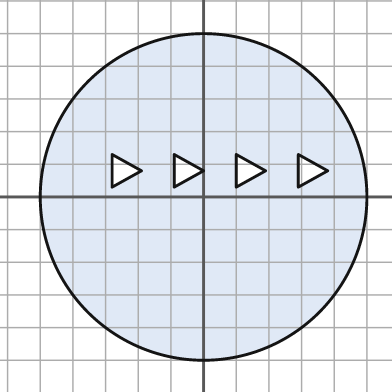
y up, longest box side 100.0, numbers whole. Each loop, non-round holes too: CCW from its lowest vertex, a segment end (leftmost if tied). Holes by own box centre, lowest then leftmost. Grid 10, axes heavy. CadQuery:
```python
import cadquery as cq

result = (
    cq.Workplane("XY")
    .moveTo(0.0, 0.0)
    .circle(50.0)
    .moveTo(-28.0, 3.0)
    .lineTo(-19.0, 8.0)
    .lineTo(-28.0, 13.0)
    .close()
    .moveTo(-9.0, 3.0)
    .lineTo(0.0, 8.0)
    .lineTo(-9.0, 13.0)
    .close()
    .moveTo(10.0, 3.0)
    .lineTo(19.0, 8.0)
    .lineTo(10.0, 13.0)
    .close()
    .moveTo(29.0, 3.0)
    .lineTo(38.0, 8.0)
    .lineTo(29.0, 13.0)
    .close()
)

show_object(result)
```